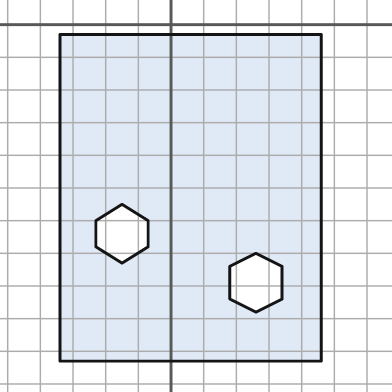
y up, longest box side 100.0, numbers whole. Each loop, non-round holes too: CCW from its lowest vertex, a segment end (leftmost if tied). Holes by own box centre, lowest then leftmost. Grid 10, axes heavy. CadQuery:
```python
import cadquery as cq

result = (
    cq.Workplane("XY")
    .moveTo(-34.0, -103.0)
    .lineTo(46.0, -103.0)
    .lineTo(46.0, -3.0)
    .lineTo(-34.0, -3.0)
    .close()
    .moveTo(26.0, -88.0)
    .lineTo(34.0, -84.0)
    .lineTo(34.0, -74.0)
    .lineTo(26.0, -70.0)
    .lineTo(18.0, -74.0)
    .lineTo(18.0, -84.0)
    .close()
    .moveTo(-15.0, -73.0)
    .lineTo(-7.0, -68.0)
    .lineTo(-7.0, -60.0)
    .lineTo(-15.0, -55.0)
    .lineTo(-23.0, -60.0)
    .lineTo(-23.0, -68.0)
    .close()
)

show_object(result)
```